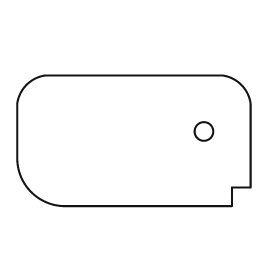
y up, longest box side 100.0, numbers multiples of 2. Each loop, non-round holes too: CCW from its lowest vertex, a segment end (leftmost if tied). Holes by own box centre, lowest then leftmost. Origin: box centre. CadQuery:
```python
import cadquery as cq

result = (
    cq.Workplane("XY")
    .moveTo(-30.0, -28.0)
    .lineTo(42.0, -28.0)
    .lineTo(42.0, -20.0)
    .lineTo(50.0, -20.0)
    .lineTo(50.0, 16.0)
    .threePointArc((46.0, 24.0), (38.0, 28.0))
    .lineTo(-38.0, 28.0)
    .threePointArc((-46.0, 24.0), (-50.0, 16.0))
    .lineTo(-50.0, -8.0)
    .threePointArc((-44.0, -22.0), (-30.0, -28.0))
    .close()
    .moveTo(30.0, 4.0)
    .circle(4.0)
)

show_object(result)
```